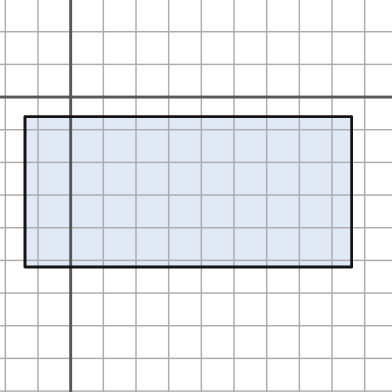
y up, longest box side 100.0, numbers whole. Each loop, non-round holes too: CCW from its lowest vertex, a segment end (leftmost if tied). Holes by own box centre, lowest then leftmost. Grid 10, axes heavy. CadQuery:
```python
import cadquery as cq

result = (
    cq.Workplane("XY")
    .moveTo(-14.0, -52.0)
    .lineTo(86.0, -52.0)
    .lineTo(86.0, -6.0)
    .lineTo(-14.0, -6.0)
    .close()
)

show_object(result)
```